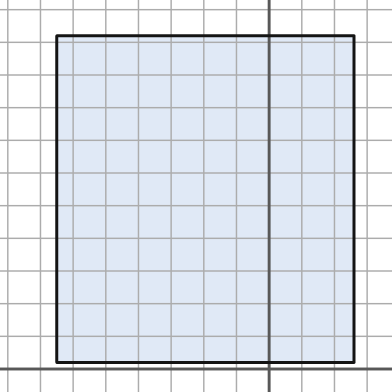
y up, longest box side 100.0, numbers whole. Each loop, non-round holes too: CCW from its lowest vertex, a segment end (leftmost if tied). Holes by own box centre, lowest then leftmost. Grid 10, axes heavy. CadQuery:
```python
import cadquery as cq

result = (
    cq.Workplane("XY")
    .moveTo(-65.0, 2.0)
    .lineTo(26.0, 2.0)
    .lineTo(26.0, 102.0)
    .lineTo(-65.0, 102.0)
    .close()
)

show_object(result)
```